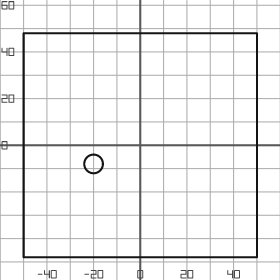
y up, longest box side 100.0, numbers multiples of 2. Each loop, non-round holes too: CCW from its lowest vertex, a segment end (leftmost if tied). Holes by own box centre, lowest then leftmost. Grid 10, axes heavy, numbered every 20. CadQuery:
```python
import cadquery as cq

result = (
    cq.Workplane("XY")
    .moveTo(-50.0, -48.0)
    .lineTo(50.0, -48.0)
    .lineTo(50.0, 48.0)
    .lineTo(-50.0, 48.0)
    .close()
    .moveTo(-20.0, -8.0)
    .circle(4.0)
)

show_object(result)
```